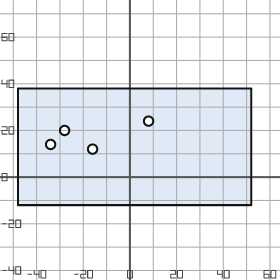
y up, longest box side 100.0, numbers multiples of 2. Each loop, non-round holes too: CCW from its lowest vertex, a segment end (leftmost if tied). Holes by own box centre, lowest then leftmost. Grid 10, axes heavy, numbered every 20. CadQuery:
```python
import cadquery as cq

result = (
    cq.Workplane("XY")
    .moveTo(-48.0, -12.0)
    .lineTo(52.0, -12.0)
    .lineTo(52.0, 38.0)
    .lineTo(-48.0, 38.0)
    .close()
    .moveTo(-16.0, 12.0)
    .circle(2.0)
    .moveTo(-34.0, 14.0)
    .circle(2.0)
    .moveTo(-28.0, 20.0)
    .circle(2.0)
    .moveTo(8.0, 24.0)
    .circle(2.0)
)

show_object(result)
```